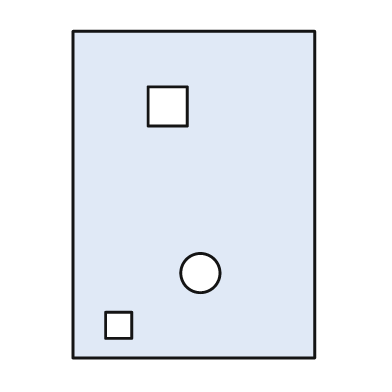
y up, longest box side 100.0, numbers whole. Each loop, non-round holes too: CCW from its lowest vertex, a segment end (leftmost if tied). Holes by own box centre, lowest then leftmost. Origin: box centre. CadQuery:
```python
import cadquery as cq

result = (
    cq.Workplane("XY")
    .moveTo(-37.0, -50.0)
    .lineTo(37.0, -50.0)
    .lineTo(37.0, 50.0)
    .lineTo(-37.0, 50.0)
    .close()
    .moveTo(-27.0, -44.0)
    .lineTo(-19.0, -44.0)
    .lineTo(-19.0, -36.0)
    .lineTo(-27.0, -36.0)
    .close()
    .moveTo(2.0, -24.0)
    .circle(6.0)
    .moveTo(-14.0, 21.0)
    .lineTo(-2.0, 21.0)
    .lineTo(-2.0, 33.0)
    .lineTo(-14.0, 33.0)
    .close()
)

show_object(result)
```